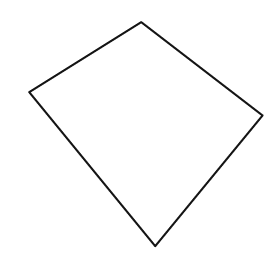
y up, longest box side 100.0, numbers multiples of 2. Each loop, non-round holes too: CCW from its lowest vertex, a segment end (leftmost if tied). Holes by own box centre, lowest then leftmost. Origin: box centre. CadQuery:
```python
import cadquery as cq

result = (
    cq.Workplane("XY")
    .moveTo(4.0, -48.0)
    .lineTo(50.0, 8.0)
    .lineTo(-2.0, 48.0)
    .lineTo(-50.0, 18.0)
    .close()
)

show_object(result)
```